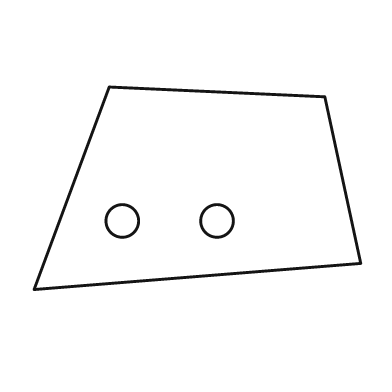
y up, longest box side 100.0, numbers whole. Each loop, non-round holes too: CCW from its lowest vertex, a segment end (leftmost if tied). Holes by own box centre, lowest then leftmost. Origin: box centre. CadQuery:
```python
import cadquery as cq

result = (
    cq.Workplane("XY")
    .moveTo(-50.0, -31.0)
    .lineTo(50.0, -23.0)
    .lineTo(39.0, 28.0)
    .lineTo(-27.0, 31.0)
    .close()
    .moveTo(-23.0, -10.0)
    .circle(5.0)
    .moveTo(6.0, -10.0)
    .circle(5.0)
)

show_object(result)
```